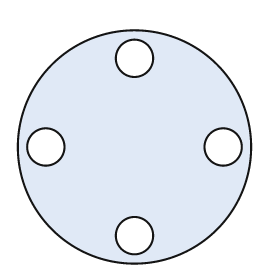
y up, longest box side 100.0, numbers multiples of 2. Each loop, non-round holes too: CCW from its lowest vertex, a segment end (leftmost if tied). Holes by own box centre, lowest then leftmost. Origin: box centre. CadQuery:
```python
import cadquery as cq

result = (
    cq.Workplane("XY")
    .moveTo(0.0, 0.0)
    .circle(50.0)
    .moveTo(0.0, -38.0)
    .circle(8.0)
    .moveTo(-38.0, 0.0)
    .circle(8.0)
    .moveTo(38.0, 0.0)
    .circle(8.0)
    .moveTo(0.0, 38.0)
    .circle(8.0)
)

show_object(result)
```